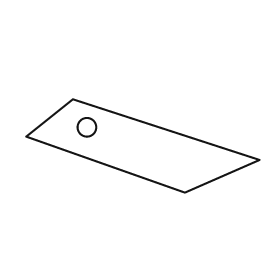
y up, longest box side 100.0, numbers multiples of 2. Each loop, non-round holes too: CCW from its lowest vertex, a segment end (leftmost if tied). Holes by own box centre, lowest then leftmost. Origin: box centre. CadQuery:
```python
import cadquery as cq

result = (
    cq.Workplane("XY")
    .moveTo(18.0, -20.0)
    .lineTo(50.0, -6.0)
    .lineTo(-30.0, 20.0)
    .lineTo(-50.0, 4.0)
    .close()
    .moveTo(-24.0, 8.0)
    .circle(4.0)
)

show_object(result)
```